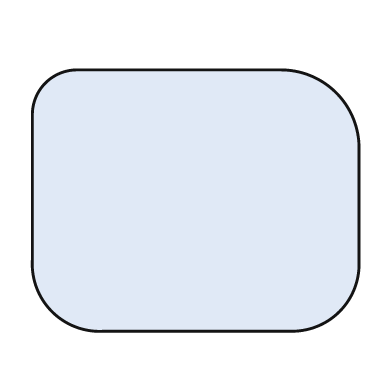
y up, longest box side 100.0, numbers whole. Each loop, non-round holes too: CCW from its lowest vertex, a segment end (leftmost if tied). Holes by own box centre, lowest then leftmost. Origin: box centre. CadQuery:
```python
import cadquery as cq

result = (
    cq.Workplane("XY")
    .moveTo(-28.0, -40.0)
    .lineTo(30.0, -40.0)
    .threePointArc((44.0, -34.0), (50.0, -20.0))
    .lineTo(50.0, 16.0)
    .threePointArc((43.0, 33.0), (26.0, 40.0))
    .lineTo(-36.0, 40.0)
    .threePointArc((-46.0, 36.0), (-50.0, 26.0))
    .lineTo(-50.0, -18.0)
    .threePointArc((-44.0, -34.0), (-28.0, -40.0))
    .close()
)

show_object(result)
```